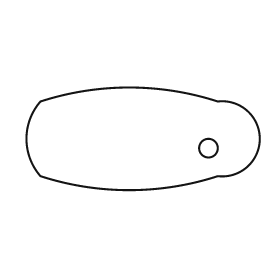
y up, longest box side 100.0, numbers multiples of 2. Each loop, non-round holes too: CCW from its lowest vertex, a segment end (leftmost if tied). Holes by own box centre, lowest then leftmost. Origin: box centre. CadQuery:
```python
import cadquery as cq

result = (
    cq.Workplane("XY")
    .moveTo(-44.0, -16.0)
    .threePointArc((-6.0, -22.0), (32.0, -16.0))
    .threePointArc((50.0, 0.0), (32.0, 16.0))
    .threePointArc((-6.0, 22.0), (-44.0, 16.0))
    .threePointArc((-50.0, 0.0), (-44.0, -16.0))
    .close()
    .moveTo(28.0, -4.0)
    .circle(4.0)
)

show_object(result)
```